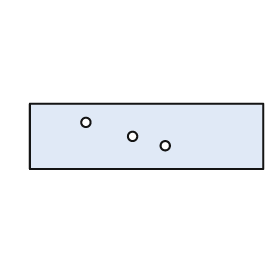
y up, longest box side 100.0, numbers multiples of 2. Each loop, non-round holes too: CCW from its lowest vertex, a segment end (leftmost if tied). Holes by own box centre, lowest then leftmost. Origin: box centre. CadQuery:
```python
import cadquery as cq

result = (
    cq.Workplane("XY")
    .moveTo(-50.0, -14.0)
    .lineTo(50.0, -14.0)
    .lineTo(50.0, 14.0)
    .lineTo(-50.0, 14.0)
    .close()
    .moveTo(8.0, -4.0)
    .circle(2.0)
    .moveTo(-6.0, 0.0)
    .circle(2.0)
    .moveTo(-26.0, 6.0)
    .circle(2.0)
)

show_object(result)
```